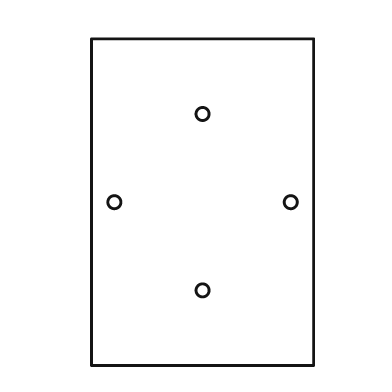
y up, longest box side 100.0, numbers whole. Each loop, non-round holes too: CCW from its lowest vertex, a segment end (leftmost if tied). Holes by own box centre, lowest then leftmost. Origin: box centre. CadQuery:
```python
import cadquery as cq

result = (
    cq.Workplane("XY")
    .moveTo(-34.0, -50.0)
    .lineTo(34.0, -50.0)
    .lineTo(34.0, 50.0)
    .lineTo(-34.0, 50.0)
    .close()
    .moveTo(0.0, -27.0)
    .circle(2.0)
    .moveTo(-27.0, 0.0)
    .circle(2.0)
    .moveTo(27.0, 0.0)
    .circle(2.0)
    .moveTo(0.0, 27.0)
    .circle(2.0)
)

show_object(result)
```